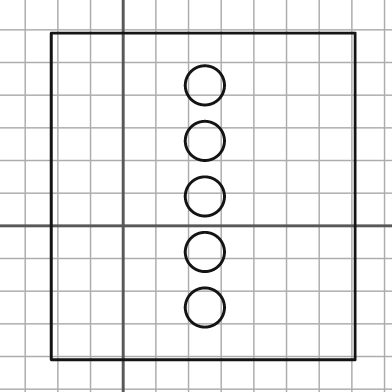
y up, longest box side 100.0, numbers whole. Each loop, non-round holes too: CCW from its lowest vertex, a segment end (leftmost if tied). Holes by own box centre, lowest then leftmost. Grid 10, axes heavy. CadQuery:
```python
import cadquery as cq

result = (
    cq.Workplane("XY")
    .moveTo(-22.0, -41.0)
    .lineTo(71.0, -41.0)
    .lineTo(71.0, 59.0)
    .lineTo(-22.0, 59.0)
    .close()
    .moveTo(25.0, -25.0)
    .circle(6.0)
    .moveTo(25.0, -8.0)
    .circle(6.0)
    .moveTo(25.0, 9.0)
    .circle(6.0)
    .moveTo(25.0, 26.0)
    .circle(6.0)
    .moveTo(25.0, 43.0)
    .circle(6.0)
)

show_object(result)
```